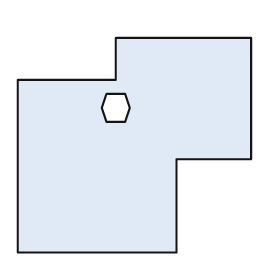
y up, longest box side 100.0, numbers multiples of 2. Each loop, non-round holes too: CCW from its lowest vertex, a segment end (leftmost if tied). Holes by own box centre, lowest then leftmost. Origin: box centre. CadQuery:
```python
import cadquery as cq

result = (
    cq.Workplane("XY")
    .moveTo(-50.0, -46.0)
    .lineTo(18.0, -46.0)
    .lineTo(18.0, -6.0)
    .lineTo(50.0, -6.0)
    .lineTo(50.0, 46.0)
    .lineTo(-8.0, 46.0)
    .lineTo(-8.0, 28.0)
    .lineTo(-50.0, 28.0)
    .close()
    .moveTo(-12.0, 10.0)
    .lineTo(-4.0, 10.0)
    .lineTo(-2.0, 16.0)
    .lineTo(-4.0, 22.0)
    .lineTo(-12.0, 22.0)
    .lineTo(-14.0, 16.0)
    .close()
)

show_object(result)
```